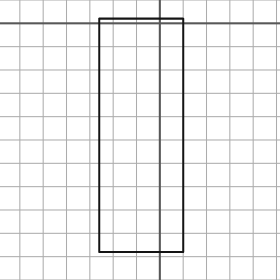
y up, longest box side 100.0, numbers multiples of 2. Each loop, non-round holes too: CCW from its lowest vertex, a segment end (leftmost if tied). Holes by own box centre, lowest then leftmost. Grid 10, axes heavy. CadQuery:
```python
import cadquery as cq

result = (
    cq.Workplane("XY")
    .moveTo(-26.0, -98.0)
    .lineTo(10.0, -98.0)
    .lineTo(10.0, 2.0)
    .lineTo(-26.0, 2.0)
    .close()
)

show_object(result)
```